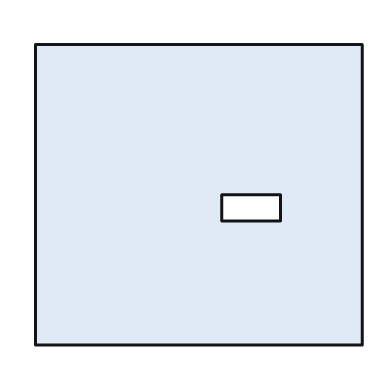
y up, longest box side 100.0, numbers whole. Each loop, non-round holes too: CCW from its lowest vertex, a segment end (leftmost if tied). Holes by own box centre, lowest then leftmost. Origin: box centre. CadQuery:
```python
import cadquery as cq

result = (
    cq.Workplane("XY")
    .moveTo(-50.0, -46.0)
    .lineTo(50.0, -46.0)
    .lineTo(50.0, 46.0)
    .lineTo(-50.0, 46.0)
    .close()
    .moveTo(7.0, -8.0)
    .lineTo(25.0, -8.0)
    .lineTo(25.0, 0.0)
    .lineTo(7.0, 0.0)
    .close()
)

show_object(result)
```